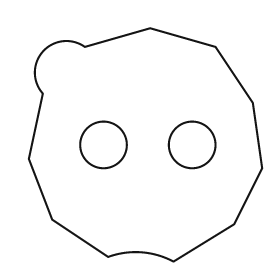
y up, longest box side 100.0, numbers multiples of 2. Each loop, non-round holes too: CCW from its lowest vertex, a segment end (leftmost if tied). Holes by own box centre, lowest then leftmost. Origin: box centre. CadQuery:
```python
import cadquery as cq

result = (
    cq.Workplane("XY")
    .moveTo(12.0, -50.0)
    .lineTo(38.0, -34.0)
    .lineTo(50.0, -10.0)
    .lineTo(46.0, 18.0)
    .lineTo(30.0, 42.0)
    .lineTo(2.0, 50.0)
    .lineTo(-26.0, 42.0)
    .threePointArc((-44.0, 40.0), (-44.0, 22.0))
    .lineTo(-50.0, -6.0)
    .lineTo(-40.0, -32.0)
    .lineTo(-16.0, -48.0)
    .threePointArc((-2.0, -46.0), (12.0, -50.0))
    .close()
    .moveTo(-18.0, 0.0)
    .circle(10.0)
    .moveTo(20.0, 0.0)
    .circle(10.0)
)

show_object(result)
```